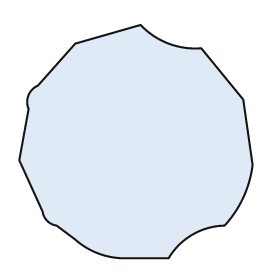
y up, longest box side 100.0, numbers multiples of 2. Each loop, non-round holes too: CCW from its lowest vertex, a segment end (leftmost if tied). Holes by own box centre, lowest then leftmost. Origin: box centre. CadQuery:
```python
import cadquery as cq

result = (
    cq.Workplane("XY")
    .moveTo(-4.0, -50.0)
    .lineTo(14.0, -50.0)
    .threePointArc((24.0, -40.0), (38.0, -36.0))
    .threePointArc((46.0, -24.0), (50.0, -10.0))
    .lineTo(46.0, 18.0)
    .lineTo(28.0, 40.0)
    .threePointArc((14.0, 42.0), (2.0, 50.0))
    .lineTo(-26.0, 42.0)
    .lineTo(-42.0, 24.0)
    .threePointArc((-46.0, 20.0), (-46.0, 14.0))
    .lineTo(-50.0, -8.0)
    .lineTo(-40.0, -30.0)
    .threePointArc((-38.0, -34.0), (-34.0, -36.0))
    .lineTo(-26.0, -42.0)
    .threePointArc((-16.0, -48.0), (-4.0, -50.0))
    .close()
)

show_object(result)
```